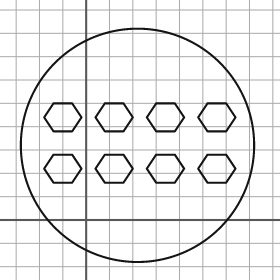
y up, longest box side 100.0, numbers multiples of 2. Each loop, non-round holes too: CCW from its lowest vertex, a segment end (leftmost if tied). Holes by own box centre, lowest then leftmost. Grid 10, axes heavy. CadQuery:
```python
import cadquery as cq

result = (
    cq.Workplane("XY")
    .moveTo(22.0, 32.0)
    .circle(50.0)
    .moveTo(-14.0, 16.0)
    .lineTo(-6.0, 16.0)
    .lineTo(-2.0, 22.0)
    .lineTo(-6.0, 28.0)
    .lineTo(-14.0, 28.0)
    .lineTo(-18.0, 22.0)
    .close()
    .moveTo(8.0, 16.0)
    .lineTo(16.0, 16.0)
    .lineTo(20.0, 22.0)
    .lineTo(16.0, 28.0)
    .lineTo(8.0, 28.0)
    .lineTo(4.0, 22.0)
    .close()
    .moveTo(30.0, 16.0)
    .lineTo(38.0, 16.0)
    .lineTo(42.0, 22.0)
    .lineTo(38.0, 28.0)
    .lineTo(30.0, 28.0)
    .lineTo(26.0, 22.0)
    .close()
    .moveTo(52.0, 16.0)
    .lineTo(60.0, 16.0)
    .lineTo(64.0, 22.0)
    .lineTo(60.0, 28.0)
    .lineTo(52.0, 28.0)
    .lineTo(48.0, 22.0)
    .close()
    .moveTo(-14.0, 38.0)
    .lineTo(-6.0, 38.0)
    .lineTo(-2.0, 44.0)
    .lineTo(-6.0, 50.0)
    .lineTo(-14.0, 50.0)
    .lineTo(-18.0, 44.0)
    .close()
    .moveTo(8.0, 38.0)
    .lineTo(16.0, 38.0)
    .lineTo(20.0, 44.0)
    .lineTo(16.0, 50.0)
    .lineTo(8.0, 50.0)
    .lineTo(4.0, 44.0)
    .close()
    .moveTo(30.0, 38.0)
    .lineTo(38.0, 38.0)
    .lineTo(42.0, 44.0)
    .lineTo(38.0, 50.0)
    .lineTo(30.0, 50.0)
    .lineTo(26.0, 44.0)
    .close()
    .moveTo(52.0, 38.0)
    .lineTo(60.0, 38.0)
    .lineTo(64.0, 44.0)
    .lineTo(60.0, 50.0)
    .lineTo(52.0, 50.0)
    .lineTo(48.0, 44.0)
    .close()
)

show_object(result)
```